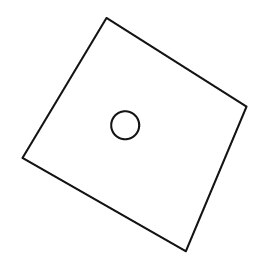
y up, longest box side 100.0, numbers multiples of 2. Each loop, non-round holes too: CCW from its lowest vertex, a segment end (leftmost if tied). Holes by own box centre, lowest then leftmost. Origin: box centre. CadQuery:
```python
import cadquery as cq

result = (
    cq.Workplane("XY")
    .moveTo(22.0, -50.0)
    .lineTo(48.0, 12.0)
    .lineTo(-12.0, 50.0)
    .lineTo(-48.0, -10.0)
    .close()
    .moveTo(-4.0, 4.0)
    .circle(6.0)
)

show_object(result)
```